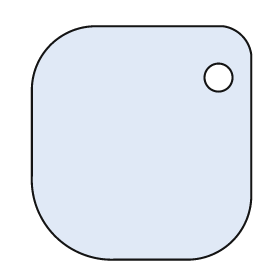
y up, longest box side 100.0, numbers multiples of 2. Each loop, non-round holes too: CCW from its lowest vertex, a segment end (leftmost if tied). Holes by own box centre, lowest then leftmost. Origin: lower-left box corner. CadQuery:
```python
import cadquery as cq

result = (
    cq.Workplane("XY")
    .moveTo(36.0, 0.0)
    .lineTo(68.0, 0.0)
    .threePointArc((86.0, 8.0), (94.0, 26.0))
    .lineTo(94.0, 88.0)
    .threePointArc((90.0, 96.0), (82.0, 100.0))
    .lineTo(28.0, 100.0)
    .threePointArc((8.0, 92.0), (0.0, 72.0))
    .lineTo(0.0, 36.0)
    .threePointArc((10.0, 10.0), (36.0, 0.0))
    .close()
    .moveTo(80.0, 78.0)
    .circle(6.0)
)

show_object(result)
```